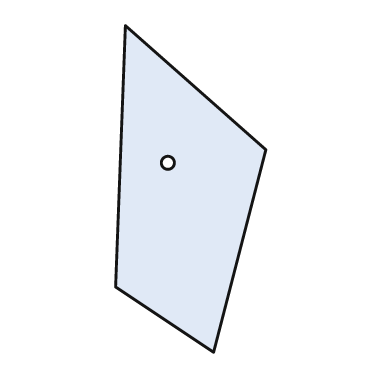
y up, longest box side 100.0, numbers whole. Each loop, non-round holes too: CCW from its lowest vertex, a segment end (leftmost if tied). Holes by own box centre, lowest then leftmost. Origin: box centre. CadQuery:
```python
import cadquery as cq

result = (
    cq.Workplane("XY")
    .moveTo(7.0, -50.0)
    .lineTo(23.0, 12.0)
    .lineTo(-20.0, 50.0)
    .lineTo(-23.0, -30.0)
    .close()
    .moveTo(-7.0, 8.0)
    .circle(2.0)
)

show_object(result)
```